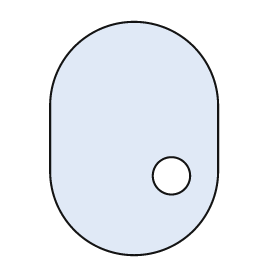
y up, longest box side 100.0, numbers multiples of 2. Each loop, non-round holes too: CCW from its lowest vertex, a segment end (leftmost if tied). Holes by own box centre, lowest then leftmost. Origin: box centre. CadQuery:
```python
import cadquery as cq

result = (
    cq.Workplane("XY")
    .moveTo(-36.0, -14.0)
    .threePointArc((0.0, -50.0), (36.0, -14.0))
    .lineTo(36.0, 14.0)
    .threePointArc((0.0, 50.0), (-36.0, 14.0))
    .close()
    .moveTo(16.0, -16.0)
    .circle(8.0)
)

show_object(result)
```